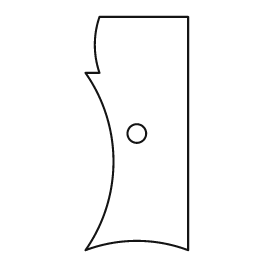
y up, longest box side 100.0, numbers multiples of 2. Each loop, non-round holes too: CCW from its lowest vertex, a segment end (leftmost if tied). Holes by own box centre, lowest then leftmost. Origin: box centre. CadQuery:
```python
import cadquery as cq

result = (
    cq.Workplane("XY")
    .moveTo(-22.0, -50.0)
    .threePointArc((0.0, -46.0), (22.0, -50.0))
    .lineTo(22.0, 50.0)
    .lineTo(-16.0, 50.0)
    .threePointArc((-18.0, 38.0), (-16.0, 26.0))
    .lineTo(-22.0, 26.0)
    .threePointArc((-10.0, -12.0), (-22.0, -50.0))
    .close()
    .moveTo(0.0, 0.0)
    .circle(4.0)
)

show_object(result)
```